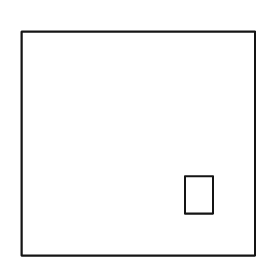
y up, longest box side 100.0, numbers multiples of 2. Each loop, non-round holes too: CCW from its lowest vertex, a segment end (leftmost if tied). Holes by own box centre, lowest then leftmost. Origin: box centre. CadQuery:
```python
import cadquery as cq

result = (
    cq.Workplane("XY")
    .moveTo(-50.0, -48.0)
    .lineTo(50.0, -48.0)
    .lineTo(50.0, 48.0)
    .lineTo(-50.0, 48.0)
    .close()
    .moveTo(20.0, -30.0)
    .lineTo(32.0, -30.0)
    .lineTo(32.0, -14.0)
    .lineTo(20.0, -14.0)
    .close()
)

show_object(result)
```